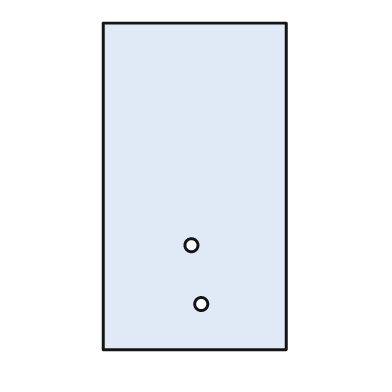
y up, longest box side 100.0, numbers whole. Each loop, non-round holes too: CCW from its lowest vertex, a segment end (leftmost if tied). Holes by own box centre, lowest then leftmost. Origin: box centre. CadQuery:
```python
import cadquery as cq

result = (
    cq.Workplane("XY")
    .moveTo(-28.0, -50.0)
    .lineTo(28.0, -50.0)
    .lineTo(28.0, 50.0)
    .lineTo(-28.0, 50.0)
    .close()
    .moveTo(2.0, -36.0)
    .circle(2.0)
    .moveTo(-1.0, -18.0)
    .circle(2.0)
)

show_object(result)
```